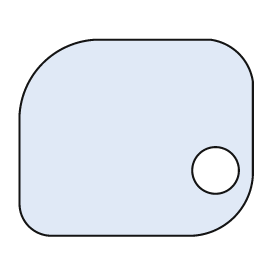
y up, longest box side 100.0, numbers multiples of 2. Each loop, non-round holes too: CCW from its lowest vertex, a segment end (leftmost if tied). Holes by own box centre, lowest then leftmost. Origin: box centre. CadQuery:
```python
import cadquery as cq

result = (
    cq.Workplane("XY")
    .moveTo(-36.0, -42.0)
    .lineTo(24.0, -42.0)
    .threePointArc((42.0, -34.0), (50.0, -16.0))
    .lineTo(50.0, 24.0)
    .threePointArc((44.0, 36.0), (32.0, 42.0))
    .lineTo(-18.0, 42.0)
    .threePointArc((-40.0, 32.0), (-50.0, 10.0))
    .lineTo(-50.0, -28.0)
    .threePointArc((-46.0, -38.0), (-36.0, -42.0))
    .close()
    .moveTo(34.0, -14.0)
    .circle(10.0)
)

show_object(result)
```